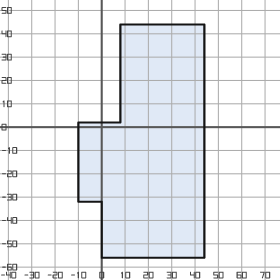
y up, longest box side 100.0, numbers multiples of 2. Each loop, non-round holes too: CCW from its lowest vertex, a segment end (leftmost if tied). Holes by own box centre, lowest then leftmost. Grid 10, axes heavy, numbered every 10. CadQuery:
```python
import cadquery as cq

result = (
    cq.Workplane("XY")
    .moveTo(0.0, -56.0)
    .lineTo(44.0, -56.0)
    .lineTo(44.0, 44.0)
    .lineTo(8.0, 44.0)
    .lineTo(8.0, 2.0)
    .lineTo(-10.0, 2.0)
    .lineTo(-10.0, -32.0)
    .lineTo(0.0, -32.0)
    .close()
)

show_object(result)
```